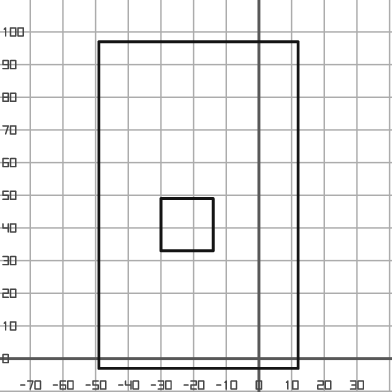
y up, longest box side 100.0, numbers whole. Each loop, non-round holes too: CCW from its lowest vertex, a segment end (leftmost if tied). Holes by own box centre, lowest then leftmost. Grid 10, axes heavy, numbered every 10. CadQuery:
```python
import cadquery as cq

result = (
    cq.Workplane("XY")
    .moveTo(-49.0, -3.0)
    .lineTo(12.0, -3.0)
    .lineTo(12.0, 97.0)
    .lineTo(-49.0, 97.0)
    .close()
    .moveTo(-30.0, 33.0)
    .lineTo(-14.0, 33.0)
    .lineTo(-14.0, 49.0)
    .lineTo(-30.0, 49.0)
    .close()
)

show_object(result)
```